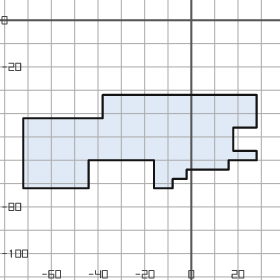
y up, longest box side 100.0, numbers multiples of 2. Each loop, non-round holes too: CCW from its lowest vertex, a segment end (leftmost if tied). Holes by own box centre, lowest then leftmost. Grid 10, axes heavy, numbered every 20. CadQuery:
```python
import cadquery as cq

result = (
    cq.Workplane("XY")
    .moveTo(-72.0, -72.0)
    .lineTo(-44.0, -72.0)
    .lineTo(-44.0, -60.0)
    .lineTo(-16.0, -60.0)
    .lineTo(-16.0, -72.0)
    .lineTo(-8.0, -72.0)
    .lineTo(-8.0, -68.0)
    .lineTo(-2.0, -68.0)
    .lineTo(-2.0, -64.0)
    .lineTo(16.0, -64.0)
    .lineTo(16.0, -60.0)
    .lineTo(28.0, -60.0)
    .lineTo(28.0, -56.0)
    .lineTo(18.0, -56.0)
    .lineTo(18.0, -46.0)
    .lineTo(28.0, -46.0)
    .lineTo(28.0, -32.0)
    .lineTo(-38.0, -32.0)
    .lineTo(-38.0, -42.0)
    .lineTo(-72.0, -42.0)
    .close()
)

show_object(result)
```